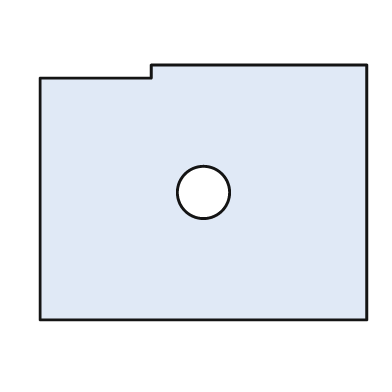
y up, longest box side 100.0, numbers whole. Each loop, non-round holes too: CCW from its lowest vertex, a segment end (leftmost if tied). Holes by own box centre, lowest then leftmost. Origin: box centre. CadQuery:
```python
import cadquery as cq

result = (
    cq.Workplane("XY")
    .moveTo(-50.0, -39.0)
    .lineTo(50.0, -39.0)
    .lineTo(50.0, 39.0)
    .lineTo(-16.0, 39.0)
    .lineTo(-16.0, 35.0)
    .lineTo(-50.0, 35.0)
    .close()
    .moveTo(0.0, 0.0)
    .circle(8.0)
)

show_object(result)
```